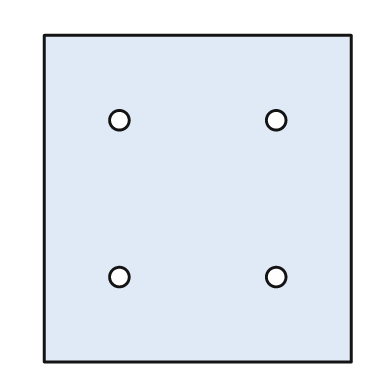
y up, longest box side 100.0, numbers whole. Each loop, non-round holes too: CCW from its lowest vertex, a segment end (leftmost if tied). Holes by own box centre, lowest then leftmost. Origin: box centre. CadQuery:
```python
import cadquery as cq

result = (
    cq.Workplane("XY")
    .moveTo(-47.0, -50.0)
    .lineTo(47.0, -50.0)
    .lineTo(47.0, 50.0)
    .lineTo(-47.0, 50.0)
    .close()
    .moveTo(-24.0, -24.0)
    .circle(3.0)
    .moveTo(24.0, -24.0)
    .circle(3.0)
    .moveTo(-24.0, 24.0)
    .circle(3.0)
    .moveTo(24.0, 24.0)
    .circle(3.0)
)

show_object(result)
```